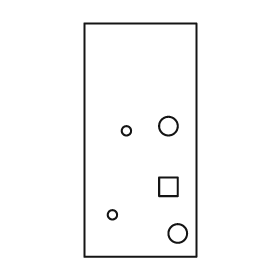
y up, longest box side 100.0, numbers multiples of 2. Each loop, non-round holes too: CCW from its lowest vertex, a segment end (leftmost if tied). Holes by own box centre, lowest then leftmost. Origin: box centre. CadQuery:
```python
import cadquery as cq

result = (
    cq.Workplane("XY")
    .moveTo(-24.0, -50.0)
    .lineTo(24.0, -50.0)
    .lineTo(24.0, 50.0)
    .lineTo(-24.0, 50.0)
    .close()
    .moveTo(16.0, -40.0)
    .circle(4.0)
    .moveTo(-12.0, -32.0)
    .circle(2.0)
    .moveTo(8.0, -24.0)
    .lineTo(16.0, -24.0)
    .lineTo(16.0, -16.0)
    .lineTo(8.0, -16.0)
    .close()
    .moveTo(-6.0, 4.0)
    .circle(2.0)
    .moveTo(12.0, 6.0)
    .circle(4.0)
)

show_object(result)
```